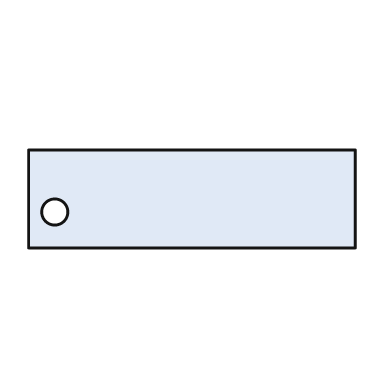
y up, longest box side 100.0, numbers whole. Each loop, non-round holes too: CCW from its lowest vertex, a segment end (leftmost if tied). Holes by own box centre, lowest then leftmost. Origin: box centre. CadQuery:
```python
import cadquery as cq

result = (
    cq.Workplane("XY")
    .moveTo(-50.0, -15.0)
    .lineTo(50.0, -15.0)
    .lineTo(50.0, 15.0)
    .lineTo(-50.0, 15.0)
    .close()
    .moveTo(-42.0, -4.0)
    .circle(4.0)
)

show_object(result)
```